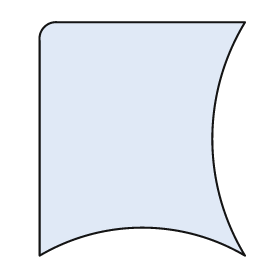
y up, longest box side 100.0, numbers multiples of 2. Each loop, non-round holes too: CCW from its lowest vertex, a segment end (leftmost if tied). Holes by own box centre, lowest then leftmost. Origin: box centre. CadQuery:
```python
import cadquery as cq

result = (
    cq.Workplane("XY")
    .moveTo(-44.0, -50.0)
    .threePointArc((0.0, -38.0), (44.0, -50.0))
    .threePointArc((30.0, 0.0), (44.0, 50.0))
    .lineTo(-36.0, 50.0)
    .threePointArc((-42.0, 48.0), (-44.0, 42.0))
    .close()
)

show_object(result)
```